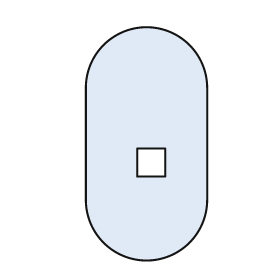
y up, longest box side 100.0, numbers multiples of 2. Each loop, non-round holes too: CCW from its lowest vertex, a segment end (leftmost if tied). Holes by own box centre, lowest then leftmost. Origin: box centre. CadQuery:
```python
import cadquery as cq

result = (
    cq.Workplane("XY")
    .moveTo(-26.0, -24.0)
    .threePointArc((0.0, -50.0), (26.0, -24.0))
    .lineTo(26.0, 24.0)
    .threePointArc((0.0, 50.0), (-26.0, 24.0))
    .close()
    .moveTo(-4.0, -14.0)
    .lineTo(8.0, -14.0)
    .lineTo(8.0, -2.0)
    .lineTo(-4.0, -2.0)
    .close()
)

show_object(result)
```